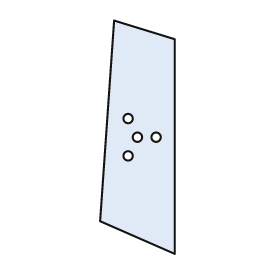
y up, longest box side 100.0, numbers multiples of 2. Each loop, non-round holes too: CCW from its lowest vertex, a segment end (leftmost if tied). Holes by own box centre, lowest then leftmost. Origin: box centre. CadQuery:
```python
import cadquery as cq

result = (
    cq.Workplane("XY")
    .moveTo(16.0, -50.0)
    .lineTo(16.0, 42.0)
    .lineTo(-10.0, 50.0)
    .lineTo(-16.0, -36.0)
    .close()
    .moveTo(-4.0, -8.0)
    .circle(2.0)
    .moveTo(0.0, 0.0)
    .circle(2.0)
    .moveTo(8.0, 0.0)
    .circle(2.0)
    .moveTo(-4.0, 8.0)
    .circle(2.0)
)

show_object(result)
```